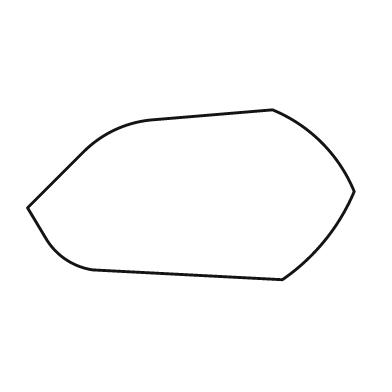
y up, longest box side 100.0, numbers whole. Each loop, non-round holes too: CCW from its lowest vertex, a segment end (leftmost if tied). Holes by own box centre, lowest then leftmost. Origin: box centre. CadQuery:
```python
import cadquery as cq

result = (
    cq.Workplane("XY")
    .moveTo(28.0, -26.0)
    .threePointArc((41.0, -14.0), (50.0, 1.0))
    .threePointArc((40.0, 16.0), (25.0, 26.0))
    .lineTo(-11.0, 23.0)
    .threePointArc((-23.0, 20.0), (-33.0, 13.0))
    .lineTo(-50.0, -4.0)
    .lineTo(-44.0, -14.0)
    .threePointArc((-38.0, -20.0), (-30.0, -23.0))
    .close()
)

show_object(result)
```